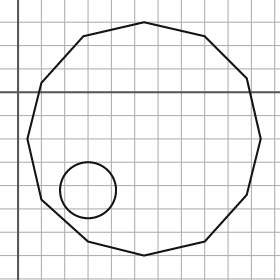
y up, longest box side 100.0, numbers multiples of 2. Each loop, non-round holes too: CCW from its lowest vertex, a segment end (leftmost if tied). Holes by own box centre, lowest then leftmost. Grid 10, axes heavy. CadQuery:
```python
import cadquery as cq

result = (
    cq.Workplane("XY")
    .moveTo(54.0, -70.0)
    .lineTo(80.0, -64.0)
    .lineTo(98.0, -44.0)
    .lineTo(104.0, -20.0)
    .lineTo(98.0, 6.0)
    .lineTo(80.0, 24.0)
    .lineTo(54.0, 30.0)
    .lineTo(28.0, 24.0)
    .lineTo(10.0, 4.0)
    .lineTo(4.0, -20.0)
    .lineTo(10.0, -46.0)
    .lineTo(30.0, -64.0)
    .close()
    .moveTo(30.0, -42.0)
    .circle(12.0)
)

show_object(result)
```